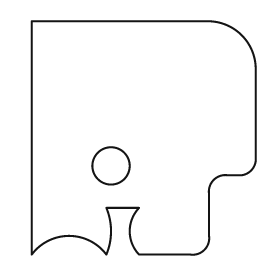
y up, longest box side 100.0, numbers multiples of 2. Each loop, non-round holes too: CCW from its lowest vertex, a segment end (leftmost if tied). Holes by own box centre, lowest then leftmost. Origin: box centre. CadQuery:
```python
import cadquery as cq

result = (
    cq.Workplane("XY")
    .moveTo(-48.0, -50.0)
    .threePointArc((-32.0, -42.0), (-16.0, -50.0))
    .threePointArc((-14.0, -40.0), (-16.0, -30.0))
    .lineTo(-2.0, -30.0)
    .threePointArc((-6.0, -40.0), (-2.0, -50.0))
    .lineTo(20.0, -50.0)
    .threePointArc((26.0, -48.0), (28.0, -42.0))
    .lineTo(28.0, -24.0)
    .threePointArc((30.0, -18.0), (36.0, -16.0))
    .lineTo(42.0, -16.0)
    .threePointArc((46.0, -14.0), (48.0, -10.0))
    .lineTo(48.0, 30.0)
    .threePointArc((42.0, 44.0), (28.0, 50.0))
    .lineTo(-48.0, 50.0)
    .close()
    .moveTo(-14.0, -12.0)
    .circle(8.0)
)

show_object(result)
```